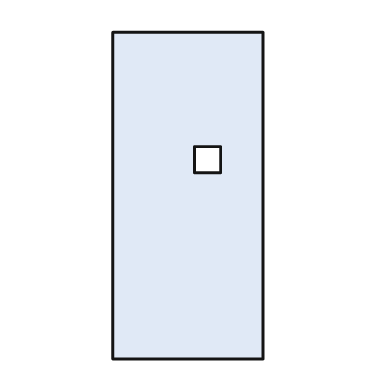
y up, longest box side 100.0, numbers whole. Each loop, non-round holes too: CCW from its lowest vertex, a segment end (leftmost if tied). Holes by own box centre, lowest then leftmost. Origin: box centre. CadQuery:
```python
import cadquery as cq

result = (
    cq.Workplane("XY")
    .moveTo(-23.0, -50.0)
    .lineTo(23.0, -50.0)
    .lineTo(23.0, 50.0)
    .lineTo(-23.0, 50.0)
    .close()
    .moveTo(2.0, 7.0)
    .lineTo(10.0, 7.0)
    .lineTo(10.0, 15.0)
    .lineTo(2.0, 15.0)
    .close()
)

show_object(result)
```